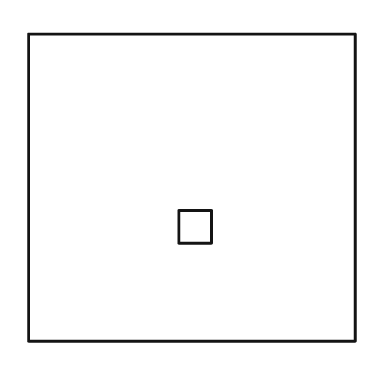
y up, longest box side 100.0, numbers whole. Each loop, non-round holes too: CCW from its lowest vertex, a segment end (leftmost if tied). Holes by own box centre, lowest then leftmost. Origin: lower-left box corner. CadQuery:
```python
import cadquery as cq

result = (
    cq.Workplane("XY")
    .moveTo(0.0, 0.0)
    .lineTo(100.0, 0.0)
    .lineTo(100.0, 94.0)
    .lineTo(0.0, 94.0)
    .close()
    .moveTo(46.0, 30.0)
    .lineTo(56.0, 30.0)
    .lineTo(56.0, 40.0)
    .lineTo(46.0, 40.0)
    .close()
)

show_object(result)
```